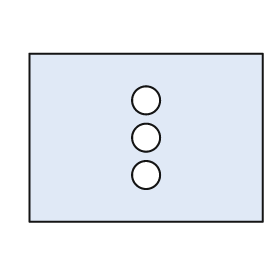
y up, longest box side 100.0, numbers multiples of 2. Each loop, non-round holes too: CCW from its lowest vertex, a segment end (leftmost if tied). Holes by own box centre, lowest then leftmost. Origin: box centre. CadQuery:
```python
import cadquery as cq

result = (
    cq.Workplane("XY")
    .moveTo(-50.0, -36.0)
    .lineTo(50.0, -36.0)
    .lineTo(50.0, 36.0)
    .lineTo(-50.0, 36.0)
    .close()
    .moveTo(0.0, -16.0)
    .circle(6.0)
    .moveTo(0.0, 0.0)
    .circle(6.0)
    .moveTo(0.0, 16.0)
    .circle(6.0)
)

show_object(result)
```